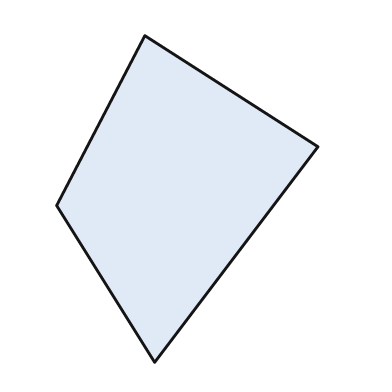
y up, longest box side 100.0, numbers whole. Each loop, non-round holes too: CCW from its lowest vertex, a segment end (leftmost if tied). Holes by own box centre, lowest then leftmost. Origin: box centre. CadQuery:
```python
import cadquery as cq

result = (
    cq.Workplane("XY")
    .moveTo(-10.0, -50.0)
    .lineTo(40.0, 16.0)
    .lineTo(-13.0, 50.0)
    .lineTo(-40.0, -2.0)
    .close()
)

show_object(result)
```